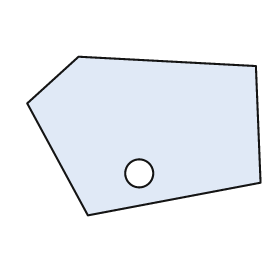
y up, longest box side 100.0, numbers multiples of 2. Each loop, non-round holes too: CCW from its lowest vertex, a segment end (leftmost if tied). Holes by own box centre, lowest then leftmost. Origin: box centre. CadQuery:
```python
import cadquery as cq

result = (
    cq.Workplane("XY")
    .moveTo(-24.0, -34.0)
    .lineTo(50.0, -20.0)
    .lineTo(48.0, 30.0)
    .lineTo(-28.0, 34.0)
    .lineTo(-50.0, 14.0)
    .close()
    .moveTo(-2.0, -16.0)
    .circle(6.0)
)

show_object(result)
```